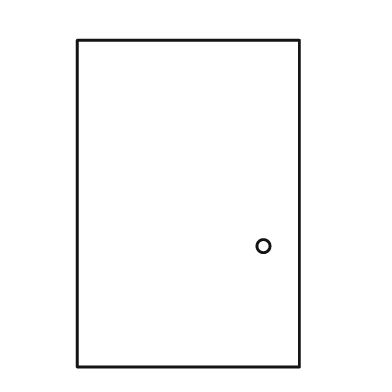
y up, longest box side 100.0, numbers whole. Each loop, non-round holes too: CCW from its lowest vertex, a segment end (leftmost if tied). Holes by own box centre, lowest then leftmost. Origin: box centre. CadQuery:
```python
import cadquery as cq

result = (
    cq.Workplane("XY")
    .moveTo(-34.0, -50.0)
    .lineTo(34.0, -50.0)
    .lineTo(34.0, 50.0)
    .lineTo(-34.0, 50.0)
    .close()
    .moveTo(23.0, -13.0)
    .circle(2.0)
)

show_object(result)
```